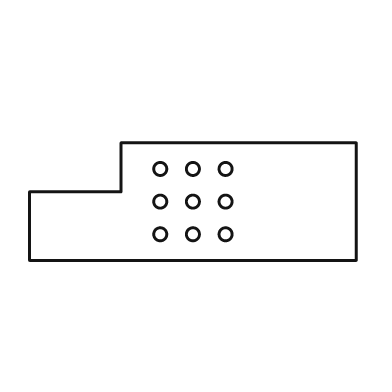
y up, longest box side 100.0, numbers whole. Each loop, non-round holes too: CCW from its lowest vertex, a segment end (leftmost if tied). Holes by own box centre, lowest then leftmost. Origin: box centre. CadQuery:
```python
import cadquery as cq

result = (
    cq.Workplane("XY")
    .moveTo(-50.0, -18.0)
    .lineTo(50.0, -18.0)
    .lineTo(50.0, 18.0)
    .lineTo(-22.0, 18.0)
    .lineTo(-22.0, 3.0)
    .lineTo(-50.0, 3.0)
    .close()
    .moveTo(-10.0, -10.0)
    .circle(2.0)
    .moveTo(0.0, -10.0)
    .circle(2.0)
    .moveTo(10.0, -10.0)
    .circle(2.0)
    .moveTo(-10.0, 0.0)
    .circle(2.0)
    .moveTo(0.0, 0.0)
    .circle(2.0)
    .moveTo(10.0, 0.0)
    .circle(2.0)
    .moveTo(-10.0, 10.0)
    .circle(2.0)
    .moveTo(0.0, 10.0)
    .circle(2.0)
    .moveTo(10.0, 10.0)
    .circle(2.0)
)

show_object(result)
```